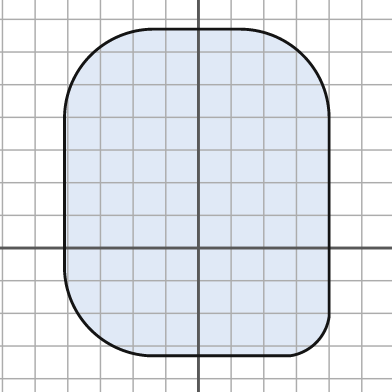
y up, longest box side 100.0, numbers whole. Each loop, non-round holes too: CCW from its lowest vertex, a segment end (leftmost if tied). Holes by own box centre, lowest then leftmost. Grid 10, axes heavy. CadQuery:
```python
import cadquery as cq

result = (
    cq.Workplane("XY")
    .moveTo(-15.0, -33.0)
    .lineTo(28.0, -33.0)
    .threePointArc((36.0, -29.0), (40.0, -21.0))
    .lineTo(40.0, 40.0)
    .threePointArc((32.0, 59.0), (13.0, 67.0))
    .lineTo(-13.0, 67.0)
    .threePointArc((-33.0, 59.0), (-41.0, 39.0))
    .lineTo(-41.0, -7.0)
    .threePointArc((-33.0, -25.0), (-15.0, -33.0))
    .close()
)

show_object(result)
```